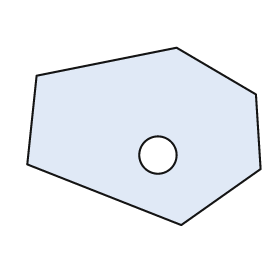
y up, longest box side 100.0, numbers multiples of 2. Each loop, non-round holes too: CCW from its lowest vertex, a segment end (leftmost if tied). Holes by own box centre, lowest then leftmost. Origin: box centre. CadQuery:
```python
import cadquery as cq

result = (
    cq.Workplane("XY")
    .moveTo(16.0, -38.0)
    .lineTo(50.0, -14.0)
    .lineTo(48.0, 18.0)
    .lineTo(14.0, 38.0)
    .lineTo(-46.0, 26.0)
    .lineTo(-50.0, -12.0)
    .close()
    .moveTo(6.0, -8.0)
    .circle(8.0)
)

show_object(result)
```